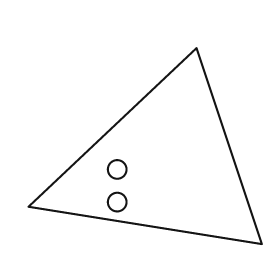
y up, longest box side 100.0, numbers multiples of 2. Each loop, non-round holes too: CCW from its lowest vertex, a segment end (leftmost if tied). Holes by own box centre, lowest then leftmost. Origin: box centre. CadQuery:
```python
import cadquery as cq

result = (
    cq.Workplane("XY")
    .moveTo(50.0, -42.0)
    .lineTo(22.0, 42.0)
    .lineTo(-50.0, -26.0)
    .close()
    .moveTo(-12.0, -24.0)
    .circle(4.0)
    .moveTo(-12.0, -10.0)
    .circle(4.0)
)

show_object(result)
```